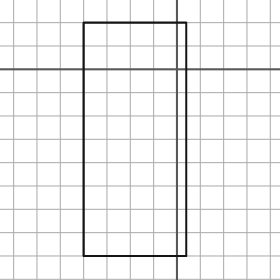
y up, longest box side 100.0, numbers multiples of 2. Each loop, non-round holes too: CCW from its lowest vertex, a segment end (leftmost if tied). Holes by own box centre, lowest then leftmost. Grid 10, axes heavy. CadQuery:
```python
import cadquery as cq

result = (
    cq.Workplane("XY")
    .moveTo(-40.0, -80.0)
    .lineTo(4.0, -80.0)
    .lineTo(4.0, 20.0)
    .lineTo(-40.0, 20.0)
    .close()
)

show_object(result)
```